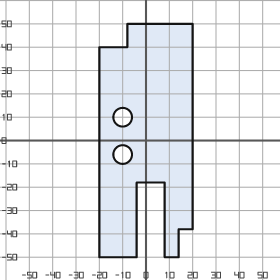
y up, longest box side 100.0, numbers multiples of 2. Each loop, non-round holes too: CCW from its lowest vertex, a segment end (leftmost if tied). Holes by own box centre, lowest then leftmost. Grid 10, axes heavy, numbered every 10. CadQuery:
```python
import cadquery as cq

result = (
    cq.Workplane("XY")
    .moveTo(-20.0, -50.0)
    .lineTo(-4.0, -50.0)
    .lineTo(-4.0, -18.0)
    .lineTo(8.0, -18.0)
    .lineTo(8.0, -50.0)
    .lineTo(14.0, -50.0)
    .lineTo(14.0, -38.0)
    .lineTo(20.0, -38.0)
    .lineTo(20.0, 50.0)
    .lineTo(-8.0, 50.0)
    .lineTo(-8.0, 40.0)
    .lineTo(-20.0, 40.0)
    .close()
    .moveTo(-10.0, -6.0)
    .circle(4.0)
    .moveTo(-10.0, 10.0)
    .circle(4.0)
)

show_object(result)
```